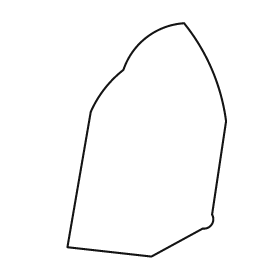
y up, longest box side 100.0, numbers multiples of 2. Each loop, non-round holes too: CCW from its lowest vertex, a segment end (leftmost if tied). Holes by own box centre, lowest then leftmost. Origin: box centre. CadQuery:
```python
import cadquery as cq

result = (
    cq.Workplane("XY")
    .moveTo(2.0, -50.0)
    .lineTo(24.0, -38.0)
    .threePointArc((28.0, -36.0), (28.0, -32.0))
    .lineTo(34.0, 8.0)
    .threePointArc((28.0, 30.0), (16.0, 50.0))
    .threePointArc((0.0, 44.0), (-10.0, 30.0))
    .threePointArc((-18.0, 22.0), (-24.0, 12.0))
    .lineTo(-34.0, -46.0)
    .close()
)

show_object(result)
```